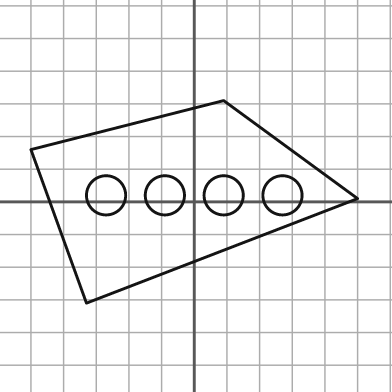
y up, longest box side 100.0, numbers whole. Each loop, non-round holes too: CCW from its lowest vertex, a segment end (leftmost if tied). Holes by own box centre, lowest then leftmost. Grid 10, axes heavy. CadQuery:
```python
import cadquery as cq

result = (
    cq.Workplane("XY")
    .moveTo(-33.0, -31.0)
    .lineTo(50.0, 1.0)
    .lineTo(9.0, 31.0)
    .lineTo(-50.0, 16.0)
    .close()
    .moveTo(-27.0, 2.0)
    .circle(6.0)
    .moveTo(-9.0, 2.0)
    .circle(6.0)
    .moveTo(9.0, 2.0)
    .circle(6.0)
    .moveTo(27.0, 2.0)
    .circle(6.0)
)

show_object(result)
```